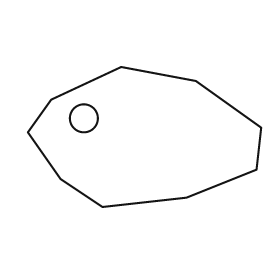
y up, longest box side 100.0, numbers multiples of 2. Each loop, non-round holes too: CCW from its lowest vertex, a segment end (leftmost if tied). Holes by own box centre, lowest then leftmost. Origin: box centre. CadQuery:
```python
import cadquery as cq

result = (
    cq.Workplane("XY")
    .moveTo(-18.0, -30.0)
    .lineTo(18.0, -26.0)
    .lineTo(48.0, -14.0)
    .lineTo(50.0, 4.0)
    .lineTo(22.0, 24.0)
    .lineTo(-10.0, 30.0)
    .lineTo(-40.0, 16.0)
    .lineTo(-50.0, 2.0)
    .lineTo(-36.0, -18.0)
    .close()
    .moveTo(-26.0, 8.0)
    .circle(6.0)
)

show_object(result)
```